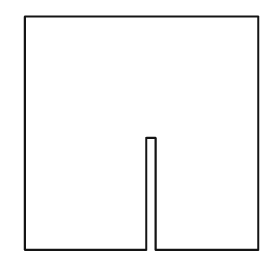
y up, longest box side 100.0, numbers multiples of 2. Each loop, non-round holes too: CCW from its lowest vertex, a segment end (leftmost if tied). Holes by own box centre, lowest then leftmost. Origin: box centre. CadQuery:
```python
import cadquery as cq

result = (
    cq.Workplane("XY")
    .moveTo(-50.0, -50.0)
    .lineTo(2.0, -50.0)
    .lineTo(2.0, -2.0)
    .lineTo(6.0, -2.0)
    .lineTo(6.0, -50.0)
    .lineTo(50.0, -50.0)
    .lineTo(50.0, 50.0)
    .lineTo(-50.0, 50.0)
    .close()
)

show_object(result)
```